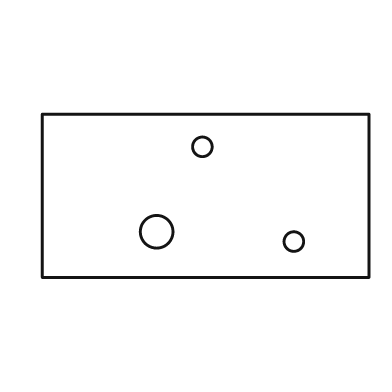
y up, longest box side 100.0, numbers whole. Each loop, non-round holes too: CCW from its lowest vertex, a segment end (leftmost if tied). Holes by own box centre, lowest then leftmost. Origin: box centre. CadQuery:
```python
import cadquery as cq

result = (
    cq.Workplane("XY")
    .moveTo(-50.0, -25.0)
    .lineTo(50.0, -25.0)
    .lineTo(50.0, 25.0)
    .lineTo(-50.0, 25.0)
    .close()
    .moveTo(27.0, -14.0)
    .circle(3.0)
    .moveTo(-15.0, -11.0)
    .circle(5.0)
    .moveTo(-1.0, 15.0)
    .circle(3.0)
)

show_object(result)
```